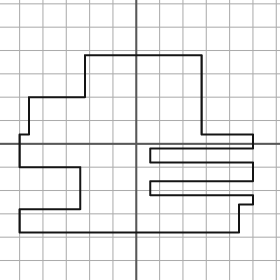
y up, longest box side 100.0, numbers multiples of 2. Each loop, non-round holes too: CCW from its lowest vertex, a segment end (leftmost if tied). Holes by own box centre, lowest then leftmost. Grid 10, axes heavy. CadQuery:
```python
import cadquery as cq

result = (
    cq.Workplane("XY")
    .moveTo(-50.0, -38.0)
    .lineTo(44.0, -38.0)
    .lineTo(44.0, -26.0)
    .lineTo(50.0, -26.0)
    .lineTo(50.0, -22.0)
    .lineTo(6.0, -22.0)
    .lineTo(6.0, -16.0)
    .lineTo(50.0, -16.0)
    .lineTo(50.0, -8.0)
    .lineTo(6.0, -8.0)
    .lineTo(6.0, -2.0)
    .lineTo(50.0, -2.0)
    .lineTo(50.0, 4.0)
    .lineTo(28.0, 4.0)
    .lineTo(28.0, 38.0)
    .lineTo(-22.0, 38.0)
    .lineTo(-22.0, 20.0)
    .lineTo(-46.0, 20.0)
    .lineTo(-46.0, 4.0)
    .lineTo(-50.0, 4.0)
    .lineTo(-50.0, -10.0)
    .lineTo(-24.0, -10.0)
    .lineTo(-24.0, -28.0)
    .lineTo(-50.0, -28.0)
    .close()
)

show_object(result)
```